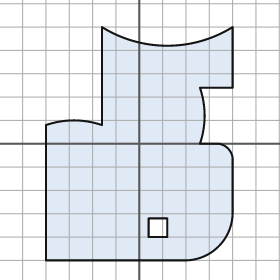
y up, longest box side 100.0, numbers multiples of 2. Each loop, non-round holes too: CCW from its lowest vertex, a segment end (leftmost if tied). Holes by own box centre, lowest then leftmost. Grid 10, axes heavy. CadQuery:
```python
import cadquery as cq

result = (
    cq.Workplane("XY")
    .moveTo(-40.0, -50.0)
    .lineTo(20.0, -50.0)
    .threePointArc((34.0, -44.0), (40.0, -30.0))
    .lineTo(40.0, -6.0)
    .threePointArc((38.0, -2.0), (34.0, 0.0))
    .lineTo(26.0, 0.0)
    .threePointArc((28.0, 12.0), (26.0, 24.0))
    .lineTo(40.0, 24.0)
    .lineTo(40.0, 50.0)
    .threePointArc((12.0, 42.0), (-16.0, 50.0))
    .lineTo(-16.0, 8.0)
    .threePointArc((-28.0, 10.0), (-40.0, 8.0))
    .close()
    .moveTo(4.0, -40.0)
    .lineTo(12.0, -40.0)
    .lineTo(12.0, -32.0)
    .lineTo(4.0, -32.0)
    .close()
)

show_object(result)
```